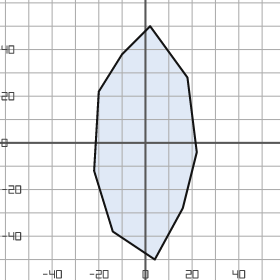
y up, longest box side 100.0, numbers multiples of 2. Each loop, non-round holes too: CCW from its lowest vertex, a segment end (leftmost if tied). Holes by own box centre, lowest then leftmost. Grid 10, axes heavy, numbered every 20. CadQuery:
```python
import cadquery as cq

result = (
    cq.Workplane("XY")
    .moveTo(4.0, -50.0)
    .lineTo(16.0, -28.0)
    .lineTo(22.0, -4.0)
    .lineTo(18.0, 28.0)
    .lineTo(2.0, 50.0)
    .lineTo(-10.0, 38.0)
    .lineTo(-20.0, 22.0)
    .lineTo(-22.0, -12.0)
    .lineTo(-14.0, -38.0)
    .close()
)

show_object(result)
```